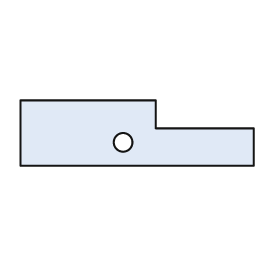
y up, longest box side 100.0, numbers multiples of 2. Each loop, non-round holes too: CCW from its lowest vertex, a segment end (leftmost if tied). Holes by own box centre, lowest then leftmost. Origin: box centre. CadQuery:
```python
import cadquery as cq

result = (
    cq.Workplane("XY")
    .moveTo(-50.0, -14.0)
    .lineTo(50.0, -14.0)
    .lineTo(50.0, 2.0)
    .lineTo(8.0, 2.0)
    .lineTo(8.0, 14.0)
    .lineTo(-50.0, 14.0)
    .close()
    .moveTo(-6.0, -4.0)
    .circle(4.0)
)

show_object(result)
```